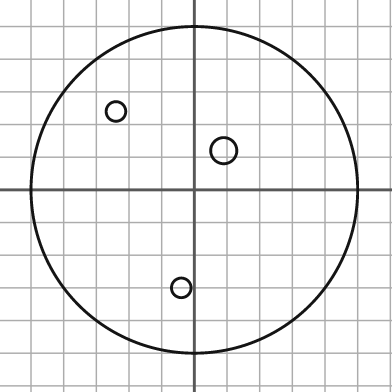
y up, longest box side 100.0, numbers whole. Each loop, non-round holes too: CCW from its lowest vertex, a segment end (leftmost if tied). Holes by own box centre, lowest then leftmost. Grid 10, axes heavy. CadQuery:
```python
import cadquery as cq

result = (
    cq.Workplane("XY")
    .moveTo(0.0, 0.0)
    .circle(50.0)
    .moveTo(-4.0, -30.0)
    .circle(3.0)
    .moveTo(9.0, 12.0)
    .circle(4.0)
    .moveTo(-24.0, 24.0)
    .circle(3.0)
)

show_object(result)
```